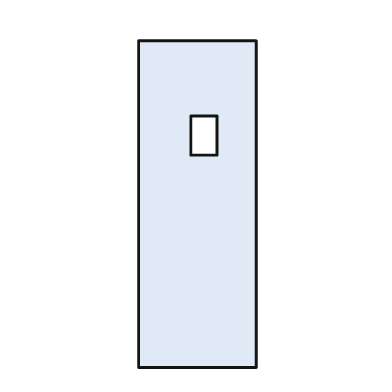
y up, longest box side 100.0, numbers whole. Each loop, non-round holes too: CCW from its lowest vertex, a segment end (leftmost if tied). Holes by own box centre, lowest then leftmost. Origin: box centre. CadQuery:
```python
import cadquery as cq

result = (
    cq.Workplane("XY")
    .moveTo(-18.0, -50.0)
    .lineTo(18.0, -50.0)
    .lineTo(18.0, 50.0)
    .lineTo(-18.0, 50.0)
    .close()
    .moveTo(-2.0, 15.0)
    .lineTo(6.0, 15.0)
    .lineTo(6.0, 27.0)
    .lineTo(-2.0, 27.0)
    .close()
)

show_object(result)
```